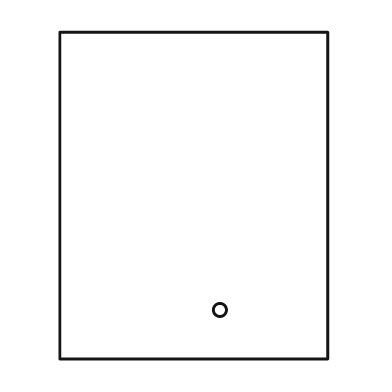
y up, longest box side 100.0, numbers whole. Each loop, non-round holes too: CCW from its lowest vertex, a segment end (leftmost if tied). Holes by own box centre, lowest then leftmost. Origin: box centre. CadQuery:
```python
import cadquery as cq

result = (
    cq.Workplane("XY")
    .moveTo(-41.0, -50.0)
    .lineTo(41.0, -50.0)
    .lineTo(41.0, 50.0)
    .lineTo(-41.0, 50.0)
    .close()
    .moveTo(8.0, -35.0)
    .circle(2.0)
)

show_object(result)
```